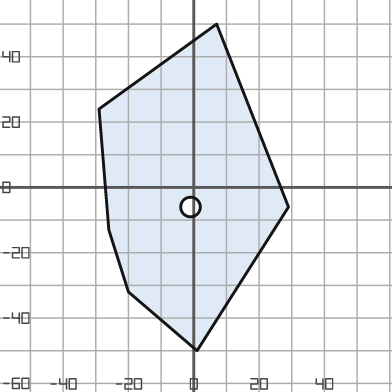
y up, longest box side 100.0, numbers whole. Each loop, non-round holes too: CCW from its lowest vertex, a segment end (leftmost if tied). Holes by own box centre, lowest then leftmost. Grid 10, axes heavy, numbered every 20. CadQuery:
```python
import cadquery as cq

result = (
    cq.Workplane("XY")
    .moveTo(1.0, -50.0)
    .lineTo(29.0, -6.0)
    .lineTo(7.0, 50.0)
    .lineTo(-29.0, 24.0)
    .lineTo(-26.0, -13.0)
    .lineTo(-20.0, -32.0)
    .close()
    .moveTo(-1.0, -6.0)
    .circle(3.0)
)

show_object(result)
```